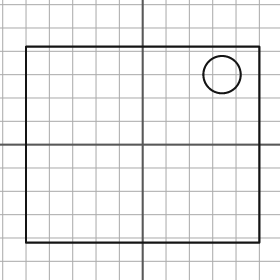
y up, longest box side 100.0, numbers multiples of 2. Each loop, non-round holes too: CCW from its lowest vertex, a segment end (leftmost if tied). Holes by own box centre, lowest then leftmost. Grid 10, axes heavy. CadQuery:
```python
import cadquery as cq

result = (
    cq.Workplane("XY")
    .moveTo(-50.0, -42.0)
    .lineTo(50.0, -42.0)
    .lineTo(50.0, 42.0)
    .lineTo(-50.0, 42.0)
    .close()
    .moveTo(34.0, 30.0)
    .circle(8.0)
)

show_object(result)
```